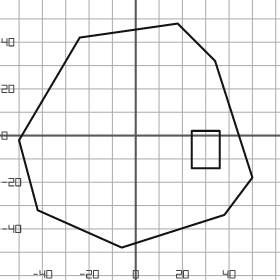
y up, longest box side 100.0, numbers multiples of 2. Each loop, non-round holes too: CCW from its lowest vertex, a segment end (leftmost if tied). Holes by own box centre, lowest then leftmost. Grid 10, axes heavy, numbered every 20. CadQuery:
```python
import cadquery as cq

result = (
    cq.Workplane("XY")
    .moveTo(-6.0, -48.0)
    .lineTo(38.0, -34.0)
    .lineTo(50.0, -18.0)
    .lineTo(34.0, 32.0)
    .lineTo(18.0, 48.0)
    .lineTo(-24.0, 42.0)
    .lineTo(-50.0, -2.0)
    .lineTo(-42.0, -32.0)
    .close()
    .moveTo(24.0, -14.0)
    .lineTo(36.0, -14.0)
    .lineTo(36.0, 2.0)
    .lineTo(24.0, 2.0)
    .close()
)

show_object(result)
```